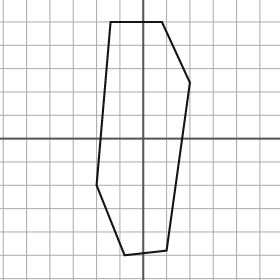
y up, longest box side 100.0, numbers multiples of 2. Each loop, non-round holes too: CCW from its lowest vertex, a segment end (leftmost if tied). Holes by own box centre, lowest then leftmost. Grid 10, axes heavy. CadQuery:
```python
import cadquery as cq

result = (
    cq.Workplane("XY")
    .moveTo(-8.0, -50.0)
    .lineTo(10.0, -48.0)
    .lineTo(20.0, 24.0)
    .lineTo(8.0, 50.0)
    .lineTo(-14.0, 50.0)
    .lineTo(-20.0, -20.0)
    .close()
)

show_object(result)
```